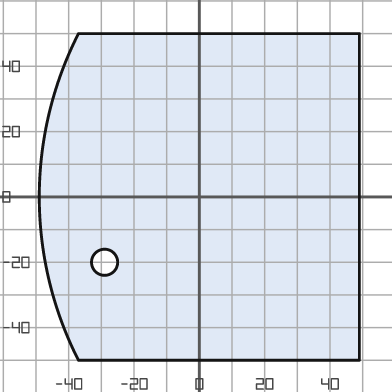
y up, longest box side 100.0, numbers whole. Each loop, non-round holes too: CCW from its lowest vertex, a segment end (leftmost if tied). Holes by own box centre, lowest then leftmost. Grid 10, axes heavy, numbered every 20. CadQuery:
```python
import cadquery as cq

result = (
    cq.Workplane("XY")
    .moveTo(-37.0, -50.0)
    .lineTo(49.0, -50.0)
    .lineTo(49.0, 50.0)
    .lineTo(-37.0, 50.0)
    .threePointArc((-49.0, 0.0), (-37.0, -50.0))
    .close()
    .moveTo(-29.0, -20.0)
    .circle(4.0)
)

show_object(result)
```